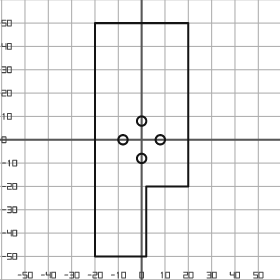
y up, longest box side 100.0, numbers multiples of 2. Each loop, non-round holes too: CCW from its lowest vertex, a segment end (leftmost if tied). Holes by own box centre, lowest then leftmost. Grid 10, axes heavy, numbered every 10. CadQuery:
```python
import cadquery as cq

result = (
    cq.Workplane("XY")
    .moveTo(-20.0, -50.0)
    .lineTo(2.0, -50.0)
    .lineTo(2.0, -20.0)
    .lineTo(20.0, -20.0)
    .lineTo(20.0, 50.0)
    .lineTo(-20.0, 50.0)
    .close()
    .moveTo(0.0, -8.0)
    .circle(2.0)
    .moveTo(-8.0, 0.0)
    .circle(2.0)
    .moveTo(8.0, 0.0)
    .circle(2.0)
    .moveTo(0.0, 8.0)
    .circle(2.0)
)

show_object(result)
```